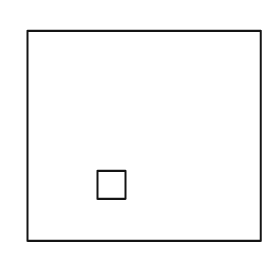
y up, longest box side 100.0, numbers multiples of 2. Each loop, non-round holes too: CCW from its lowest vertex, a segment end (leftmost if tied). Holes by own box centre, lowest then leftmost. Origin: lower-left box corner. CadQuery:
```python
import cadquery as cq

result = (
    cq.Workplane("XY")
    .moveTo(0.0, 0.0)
    .lineTo(100.0, 0.0)
    .lineTo(100.0, 90.0)
    .lineTo(0.0, 90.0)
    .close()
    .moveTo(30.0, 18.0)
    .lineTo(42.0, 18.0)
    .lineTo(42.0, 30.0)
    .lineTo(30.0, 30.0)
    .close()
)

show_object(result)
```